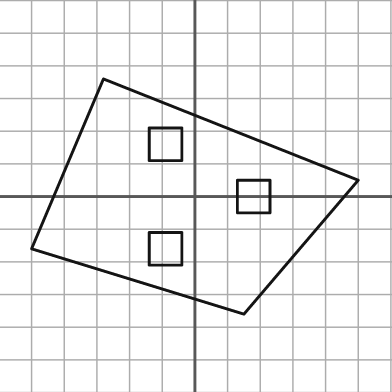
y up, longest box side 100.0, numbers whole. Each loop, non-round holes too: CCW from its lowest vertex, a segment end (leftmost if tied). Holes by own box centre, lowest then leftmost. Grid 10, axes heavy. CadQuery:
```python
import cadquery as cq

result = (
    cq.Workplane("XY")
    .moveTo(15.0, -36.0)
    .lineTo(50.0, 5.0)
    .lineTo(-28.0, 36.0)
    .lineTo(-50.0, -16.0)
    .close()
    .moveTo(-14.0, -21.0)
    .lineTo(-4.0, -21.0)
    .lineTo(-4.0, -11.0)
    .lineTo(-14.0, -11.0)
    .close()
    .moveTo(13.0, -5.0)
    .lineTo(23.0, -5.0)
    .lineTo(23.0, 5.0)
    .lineTo(13.0, 5.0)
    .close()
    .moveTo(-14.0, 11.0)
    .lineTo(-4.0, 11.0)
    .lineTo(-4.0, 21.0)
    .lineTo(-14.0, 21.0)
    .close()
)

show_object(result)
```